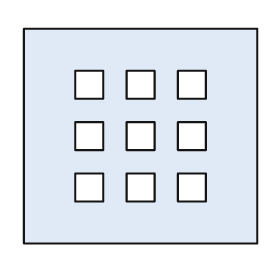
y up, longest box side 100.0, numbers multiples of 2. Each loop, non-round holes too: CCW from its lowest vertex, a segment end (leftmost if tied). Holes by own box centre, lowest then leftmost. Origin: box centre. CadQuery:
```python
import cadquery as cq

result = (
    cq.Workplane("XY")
    .moveTo(-50.0, -46.0)
    .lineTo(50.0, -46.0)
    .lineTo(50.0, 46.0)
    .lineTo(-50.0, 46.0)
    .close()
    .moveTo(-28.0, -28.0)
    .lineTo(-16.0, -28.0)
    .lineTo(-16.0, -16.0)
    .lineTo(-28.0, -16.0)
    .close()
    .moveTo(-6.0, -28.0)
    .lineTo(6.0, -28.0)
    .lineTo(6.0, -16.0)
    .lineTo(-6.0, -16.0)
    .close()
    .moveTo(16.0, -28.0)
    .lineTo(28.0, -28.0)
    .lineTo(28.0, -16.0)
    .lineTo(16.0, -16.0)
    .close()
    .moveTo(-28.0, -6.0)
    .lineTo(-16.0, -6.0)
    .lineTo(-16.0, 6.0)
    .lineTo(-28.0, 6.0)
    .close()
    .moveTo(-6.0, -6.0)
    .lineTo(6.0, -6.0)
    .lineTo(6.0, 6.0)
    .lineTo(-6.0, 6.0)
    .close()
    .moveTo(16.0, -6.0)
    .lineTo(28.0, -6.0)
    .lineTo(28.0, 6.0)
    .lineTo(16.0, 6.0)
    .close()
    .moveTo(-28.0, 16.0)
    .lineTo(-16.0, 16.0)
    .lineTo(-16.0, 28.0)
    .lineTo(-28.0, 28.0)
    .close()
    .moveTo(-6.0, 16.0)
    .lineTo(6.0, 16.0)
    .lineTo(6.0, 28.0)
    .lineTo(-6.0, 28.0)
    .close()
    .moveTo(16.0, 16.0)
    .lineTo(28.0, 16.0)
    .lineTo(28.0, 28.0)
    .lineTo(16.0, 28.0)
    .close()
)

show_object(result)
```